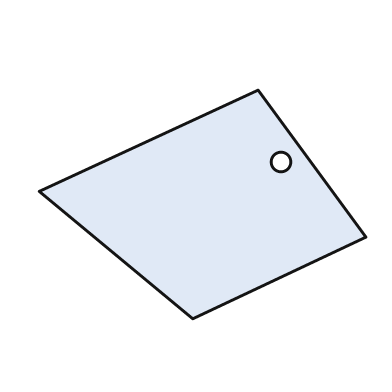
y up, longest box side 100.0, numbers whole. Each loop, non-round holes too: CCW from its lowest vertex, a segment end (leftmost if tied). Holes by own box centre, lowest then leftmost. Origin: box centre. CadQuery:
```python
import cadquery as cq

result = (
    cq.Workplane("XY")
    .moveTo(-3.0, -35.0)
    .lineTo(50.0, -10.0)
    .lineTo(17.0, 35.0)
    .lineTo(-50.0, 4.0)
    .close()
    .moveTo(24.0, 13.0)
    .circle(3.0)
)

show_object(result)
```